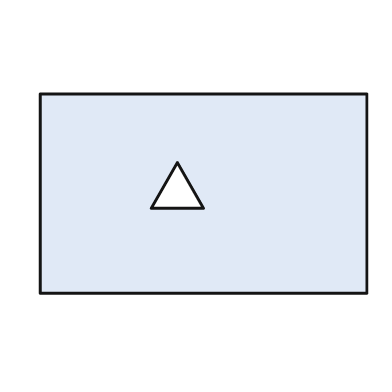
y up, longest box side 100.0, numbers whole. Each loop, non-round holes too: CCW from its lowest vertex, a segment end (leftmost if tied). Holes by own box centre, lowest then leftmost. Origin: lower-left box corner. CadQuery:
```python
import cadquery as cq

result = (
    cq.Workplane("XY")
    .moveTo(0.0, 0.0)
    .lineTo(100.0, 0.0)
    .lineTo(100.0, 61.0)
    .lineTo(0.0, 61.0)
    .close()
    .moveTo(34.0, 26.0)
    .lineTo(50.0, 26.0)
    .lineTo(42.0, 40.0)
    .close()
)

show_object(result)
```